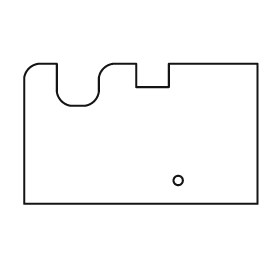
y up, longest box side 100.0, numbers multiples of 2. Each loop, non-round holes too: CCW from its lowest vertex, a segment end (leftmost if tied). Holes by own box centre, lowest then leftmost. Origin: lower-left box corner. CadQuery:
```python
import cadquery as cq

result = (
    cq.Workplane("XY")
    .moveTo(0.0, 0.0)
    .lineTo(100.0, 0.0)
    .lineTo(100.0, 60.0)
    .lineTo(62.0, 60.0)
    .lineTo(62.0, 50.0)
    .lineTo(48.0, 50.0)
    .lineTo(48.0, 60.0)
    .lineTo(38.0, 60.0)
    .threePointArc((34.0, 58.0), (32.0, 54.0))
    .lineTo(32.0, 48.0)
    .threePointArc((30.0, 44.0), (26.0, 42.0))
    .lineTo(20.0, 42.0)
    .threePointArc((16.0, 44.0), (14.0, 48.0))
    .lineTo(14.0, 60.0)
    .lineTo(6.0, 60.0)
    .threePointArc((2.0, 58.0), (0.0, 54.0))
    .close()
    .moveTo(66.0, 10.0)
    .circle(2.0)
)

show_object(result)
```